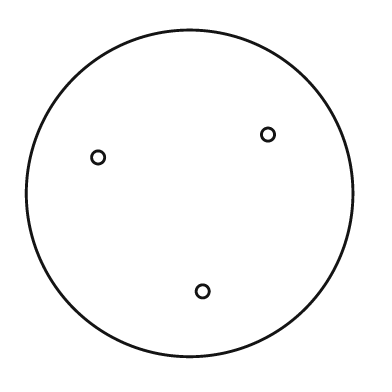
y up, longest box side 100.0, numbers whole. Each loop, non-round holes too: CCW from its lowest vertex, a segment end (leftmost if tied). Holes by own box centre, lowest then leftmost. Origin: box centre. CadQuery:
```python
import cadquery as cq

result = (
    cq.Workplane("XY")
    .moveTo(0.0, 0.0)
    .circle(50.0)
    .moveTo(4.0, -30.0)
    .circle(2.0)
    .moveTo(-28.0, 11.0)
    .circle(2.0)
    .moveTo(24.0, 18.0)
    .circle(2.0)
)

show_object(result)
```